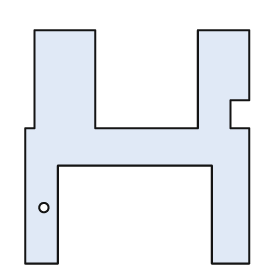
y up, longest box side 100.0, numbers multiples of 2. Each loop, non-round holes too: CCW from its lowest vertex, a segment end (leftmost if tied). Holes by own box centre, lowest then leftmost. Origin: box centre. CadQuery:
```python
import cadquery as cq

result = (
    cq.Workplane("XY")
    .moveTo(-48.0, -50.0)
    .lineTo(-34.0, -50.0)
    .lineTo(-34.0, -8.0)
    .lineTo(32.0, -8.0)
    .lineTo(32.0, -50.0)
    .lineTo(48.0, -50.0)
    .lineTo(48.0, 8.0)
    .lineTo(40.0, 8.0)
    .lineTo(40.0, 20.0)
    .lineTo(48.0, 20.0)
    .lineTo(48.0, 50.0)
    .lineTo(26.0, 50.0)
    .lineTo(26.0, 8.0)
    .lineTo(-18.0, 8.0)
    .lineTo(-18.0, 50.0)
    .lineTo(-44.0, 50.0)
    .lineTo(-44.0, 8.0)
    .lineTo(-48.0, 8.0)
    .close()
    .moveTo(-40.0, -26.0)
    .circle(2.0)
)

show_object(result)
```